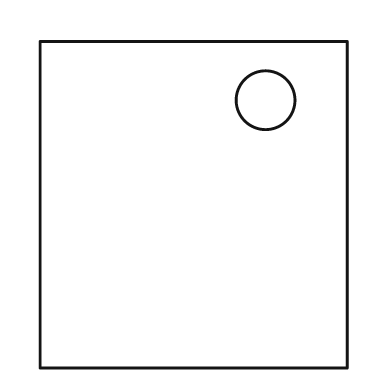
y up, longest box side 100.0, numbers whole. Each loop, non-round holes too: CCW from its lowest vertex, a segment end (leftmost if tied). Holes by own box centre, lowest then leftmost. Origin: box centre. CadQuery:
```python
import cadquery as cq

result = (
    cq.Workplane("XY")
    .moveTo(-47.0, -50.0)
    .lineTo(47.0, -50.0)
    .lineTo(47.0, 50.0)
    .lineTo(-47.0, 50.0)
    .close()
    .moveTo(22.0, 32.0)
    .circle(9.0)
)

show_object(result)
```